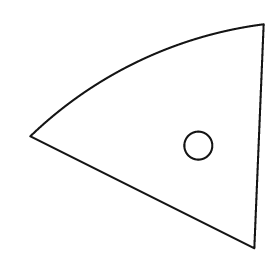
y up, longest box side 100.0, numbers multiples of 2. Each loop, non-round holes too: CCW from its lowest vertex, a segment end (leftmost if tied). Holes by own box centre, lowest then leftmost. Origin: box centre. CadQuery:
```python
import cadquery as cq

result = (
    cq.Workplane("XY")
    .moveTo(46.0, -48.0)
    .lineTo(50.0, 48.0)
    .threePointArc((-4.0, 32.0), (-50.0, 0.0))
    .close()
    .moveTo(22.0, -4.0)
    .circle(6.0)
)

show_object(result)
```